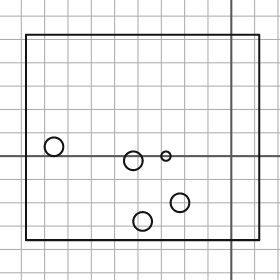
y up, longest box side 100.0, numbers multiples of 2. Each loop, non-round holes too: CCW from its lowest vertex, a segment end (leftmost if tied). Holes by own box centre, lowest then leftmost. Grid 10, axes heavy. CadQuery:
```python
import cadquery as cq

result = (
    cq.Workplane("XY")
    .moveTo(-88.0, -36.0)
    .lineTo(12.0, -36.0)
    .lineTo(12.0, 52.0)
    .lineTo(-88.0, 52.0)
    .close()
    .moveTo(-38.0, -28.0)
    .circle(4.0)
    .moveTo(-22.0, -20.0)
    .circle(4.0)
    .moveTo(-42.0, -2.0)
    .circle(4.0)
    .moveTo(-28.0, 0.0)
    .circle(2.0)
    .moveTo(-76.0, 4.0)
    .circle(4.0)
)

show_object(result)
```